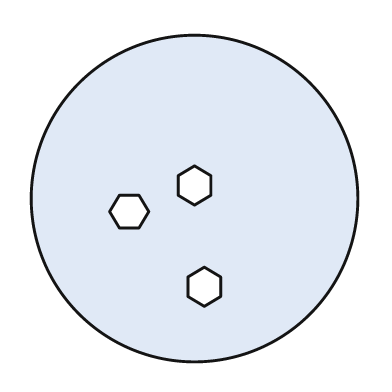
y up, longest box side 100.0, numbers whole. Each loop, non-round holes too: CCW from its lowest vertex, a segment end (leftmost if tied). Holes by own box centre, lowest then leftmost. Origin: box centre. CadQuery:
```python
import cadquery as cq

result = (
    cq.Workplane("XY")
    .moveTo(0.0, 0.0)
    .circle(50.0)
    .moveTo(3.0, -33.0)
    .lineTo(8.0, -30.0)
    .lineTo(8.0, -24.0)
    .lineTo(3.0, -21.0)
    .lineTo(-2.0, -24.0)
    .lineTo(-2.0, -30.0)
    .close()
    .moveTo(-23.0, -9.0)
    .lineTo(-17.0, -9.0)
    .lineTo(-14.0, -4.0)
    .lineTo(-17.0, 1.0)
    .lineTo(-23.0, 1.0)
    .lineTo(-26.0, -4.0)
    .close()
    .moveTo(0.0, -2.0)
    .lineTo(5.0, 1.0)
    .lineTo(5.0, 7.0)
    .lineTo(0.0, 10.0)
    .lineTo(-5.0, 7.0)
    .lineTo(-5.0, 1.0)
    .close()
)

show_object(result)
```